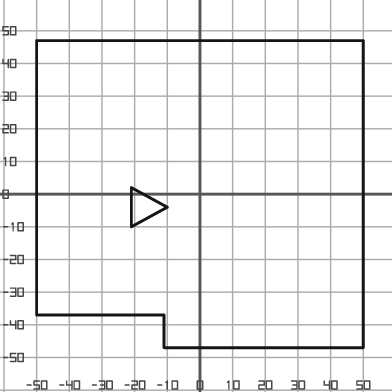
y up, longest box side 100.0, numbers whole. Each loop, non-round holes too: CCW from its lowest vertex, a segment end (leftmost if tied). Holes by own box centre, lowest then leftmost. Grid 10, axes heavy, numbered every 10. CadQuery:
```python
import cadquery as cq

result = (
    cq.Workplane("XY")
    .moveTo(-11.0, -47.0)
    .lineTo(50.0, -47.0)
    .lineTo(50.0, 47.0)
    .lineTo(-50.0, 47.0)
    .lineTo(-50.0, -37.0)
    .lineTo(-11.0, -37.0)
    .close()
    .moveTo(-21.0, -10.0)
    .lineTo(-10.0, -4.0)
    .lineTo(-21.0, 2.0)
    .close()
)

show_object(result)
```